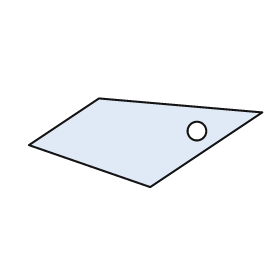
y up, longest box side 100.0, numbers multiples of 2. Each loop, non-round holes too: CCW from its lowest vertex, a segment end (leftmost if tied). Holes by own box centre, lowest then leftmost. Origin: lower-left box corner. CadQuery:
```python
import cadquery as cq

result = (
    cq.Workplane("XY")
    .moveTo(52.0, 0.0)
    .lineTo(100.0, 32.0)
    .lineTo(30.0, 38.0)
    .lineTo(0.0, 18.0)
    .close()
    .moveTo(72.0, 24.0)
    .circle(4.0)
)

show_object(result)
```